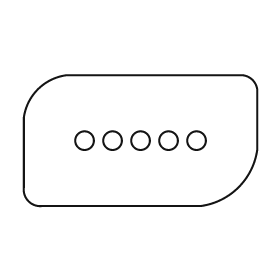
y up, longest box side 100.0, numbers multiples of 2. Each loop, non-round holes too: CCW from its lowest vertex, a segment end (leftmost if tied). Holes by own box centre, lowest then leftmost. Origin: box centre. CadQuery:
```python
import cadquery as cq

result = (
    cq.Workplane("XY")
    .moveTo(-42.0, -28.0)
    .lineTo(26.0, -28.0)
    .threePointArc((42.0, -20.0), (50.0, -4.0))
    .lineTo(50.0, 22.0)
    .threePointArc((48.0, 26.0), (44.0, 28.0))
    .lineTo(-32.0, 28.0)
    .threePointArc((-44.0, 22.0), (-50.0, 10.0))
    .lineTo(-50.0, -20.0)
    .threePointArc((-48.0, -26.0), (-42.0, -28.0))
    .close()
    .moveTo(-24.0, 0.0)
    .circle(4.0)
    .moveTo(-12.0, 0.0)
    .circle(4.0)
    .moveTo(0.0, 0.0)
    .circle(4.0)
    .moveTo(12.0, 0.0)
    .circle(4.0)
    .moveTo(24.0, 0.0)
    .circle(4.0)
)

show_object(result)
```